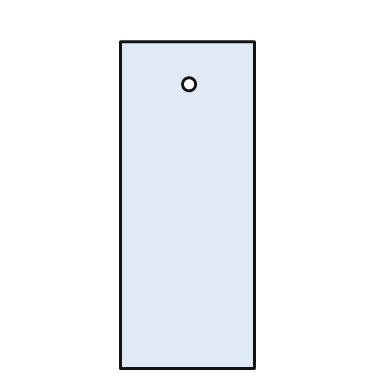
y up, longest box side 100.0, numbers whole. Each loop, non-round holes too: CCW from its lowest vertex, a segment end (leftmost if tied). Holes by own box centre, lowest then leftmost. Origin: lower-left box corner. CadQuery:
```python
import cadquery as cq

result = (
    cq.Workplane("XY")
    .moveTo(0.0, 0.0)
    .lineTo(41.0, 0.0)
    .lineTo(41.0, 100.0)
    .lineTo(0.0, 100.0)
    .close()
    .moveTo(21.0, 87.0)
    .circle(2.0)
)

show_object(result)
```